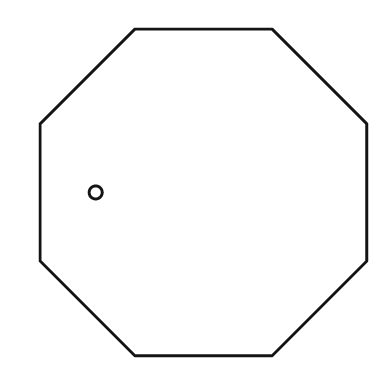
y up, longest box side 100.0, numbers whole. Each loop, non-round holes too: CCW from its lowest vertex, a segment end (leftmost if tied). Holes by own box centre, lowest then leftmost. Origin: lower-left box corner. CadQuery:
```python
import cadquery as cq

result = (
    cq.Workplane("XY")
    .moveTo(29.0, 0.0)
    .lineTo(71.0, 0.0)
    .lineTo(100.0, 29.0)
    .lineTo(100.0, 71.0)
    .lineTo(71.0, 100.0)
    .lineTo(29.0, 100.0)
    .lineTo(0.0, 71.0)
    .lineTo(0.0, 29.0)
    .close()
    .moveTo(17.0, 50.0)
    .circle(2.0)
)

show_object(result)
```